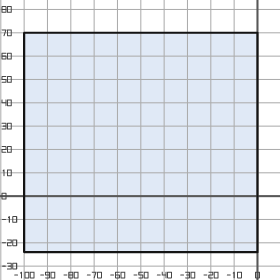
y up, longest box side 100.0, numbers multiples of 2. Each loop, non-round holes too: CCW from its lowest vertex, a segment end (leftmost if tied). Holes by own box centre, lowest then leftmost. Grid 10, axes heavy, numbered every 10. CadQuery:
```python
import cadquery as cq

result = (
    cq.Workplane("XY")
    .moveTo(-100.0, -24.0)
    .lineTo(0.0, -24.0)
    .lineTo(0.0, 70.0)
    .lineTo(-100.0, 70.0)
    .close()
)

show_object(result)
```